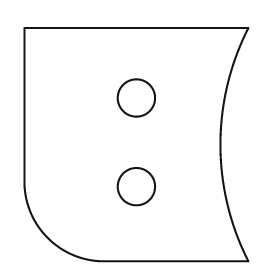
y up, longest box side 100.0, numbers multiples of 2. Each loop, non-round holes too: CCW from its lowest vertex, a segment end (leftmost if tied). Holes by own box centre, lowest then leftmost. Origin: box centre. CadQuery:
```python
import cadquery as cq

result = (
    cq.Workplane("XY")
    .moveTo(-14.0, -50.0)
    .lineTo(48.0, -50.0)
    .threePointArc((36.0, 0.0), (48.0, 50.0))
    .lineTo(-48.0, 50.0)
    .lineTo(-48.0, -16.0)
    .threePointArc((-38.0, -40.0), (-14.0, -50.0))
    .close()
    .moveTo(0.0, -18.0)
    .circle(8.0)
    .moveTo(0.0, 20.0)
    .circle(8.0)
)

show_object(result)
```